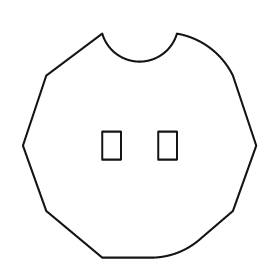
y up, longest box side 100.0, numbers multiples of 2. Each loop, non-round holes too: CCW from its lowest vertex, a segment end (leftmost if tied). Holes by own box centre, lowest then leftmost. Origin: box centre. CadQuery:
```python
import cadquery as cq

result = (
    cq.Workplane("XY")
    .moveTo(-16.0, -48.0)
    .lineTo(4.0, -48.0)
    .threePointArc((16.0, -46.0), (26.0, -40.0))
    .lineTo(40.0, -28.0)
    .lineTo(50.0, 0.0)
    .lineTo(40.0, 30.0)
    .threePointArc((30.0, 42.0), (16.0, 48.0))
    .threePointArc((0.0, 36.0), (-16.0, 48.0))
    .lineTo(-40.0, 30.0)
    .lineTo(-50.0, 0.0)
    .lineTo(-40.0, -28.0)
    .close()
    .moveTo(-16.0, -6.0)
    .lineTo(-8.0, -6.0)
    .lineTo(-8.0, 6.0)
    .lineTo(-16.0, 6.0)
    .close()
    .moveTo(8.0, -6.0)
    .lineTo(16.0, -6.0)
    .lineTo(16.0, 6.0)
    .lineTo(8.0, 6.0)
    .close()
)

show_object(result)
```